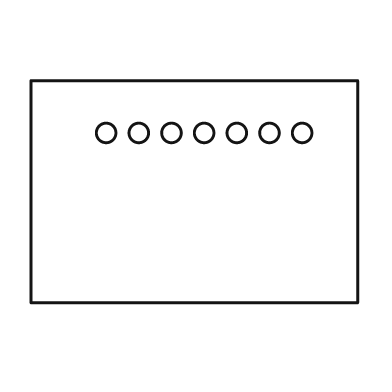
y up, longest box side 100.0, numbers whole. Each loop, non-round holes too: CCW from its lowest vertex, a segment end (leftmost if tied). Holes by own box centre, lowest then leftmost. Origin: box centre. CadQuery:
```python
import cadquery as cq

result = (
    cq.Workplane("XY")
    .moveTo(-50.0, -34.0)
    .lineTo(50.0, -34.0)
    .lineTo(50.0, 34.0)
    .lineTo(-50.0, 34.0)
    .close()
    .moveTo(-27.0, 18.0)
    .circle(3.0)
    .moveTo(-17.0, 18.0)
    .circle(3.0)
    .moveTo(-7.0, 18.0)
    .circle(3.0)
    .moveTo(3.0, 18.0)
    .circle(3.0)
    .moveTo(13.0, 18.0)
    .circle(3.0)
    .moveTo(23.0, 18.0)
    .circle(3.0)
    .moveTo(33.0, 18.0)
    .circle(3.0)
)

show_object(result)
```